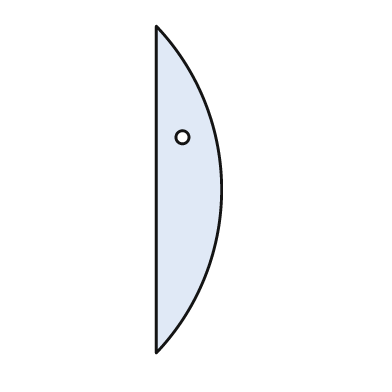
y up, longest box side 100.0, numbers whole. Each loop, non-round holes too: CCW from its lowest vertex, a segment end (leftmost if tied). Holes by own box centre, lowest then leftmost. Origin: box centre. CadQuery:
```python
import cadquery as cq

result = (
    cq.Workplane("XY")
    .moveTo(-10.0, -50.0)
    .threePointArc((10.0, 0.0), (-10.0, 50.0))
    .close()
    .moveTo(-2.0, 16.0)
    .circle(2.0)
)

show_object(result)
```